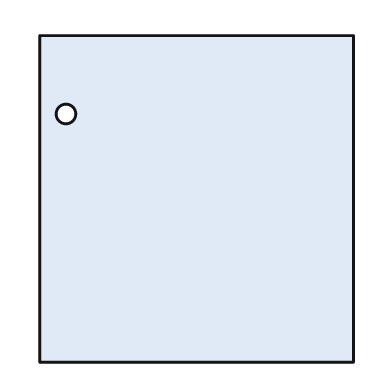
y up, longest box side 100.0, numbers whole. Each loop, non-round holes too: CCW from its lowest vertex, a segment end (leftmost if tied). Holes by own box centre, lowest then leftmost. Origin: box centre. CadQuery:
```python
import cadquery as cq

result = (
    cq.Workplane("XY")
    .moveTo(-48.0, -50.0)
    .lineTo(48.0, -50.0)
    .lineTo(48.0, 50.0)
    .lineTo(-48.0, 50.0)
    .close()
    .moveTo(-40.0, 26.0)
    .circle(3.0)
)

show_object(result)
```